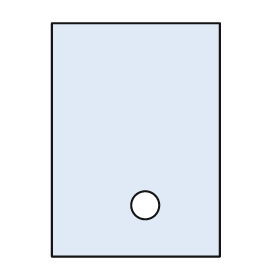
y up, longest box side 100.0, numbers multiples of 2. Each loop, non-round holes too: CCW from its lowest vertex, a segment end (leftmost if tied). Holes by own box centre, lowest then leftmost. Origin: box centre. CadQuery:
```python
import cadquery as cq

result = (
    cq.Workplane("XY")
    .moveTo(-36.0, -50.0)
    .lineTo(36.0, -50.0)
    .lineTo(36.0, 50.0)
    .lineTo(-36.0, 50.0)
    .close()
    .moveTo(4.0, -28.0)
    .circle(6.0)
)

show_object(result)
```